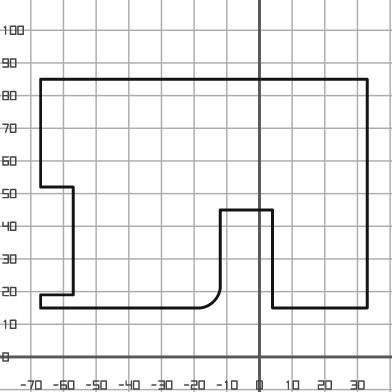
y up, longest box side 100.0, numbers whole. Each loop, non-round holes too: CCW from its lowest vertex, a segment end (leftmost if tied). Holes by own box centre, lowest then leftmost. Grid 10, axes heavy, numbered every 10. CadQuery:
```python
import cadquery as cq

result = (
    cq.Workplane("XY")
    .moveTo(-67.0, 15.0)
    .lineTo(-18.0, 15.0)
    .threePointArc((-14.0, 17.0), (-12.0, 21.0))
    .lineTo(-12.0, 45.0)
    .lineTo(4.0, 45.0)
    .lineTo(4.0, 15.0)
    .lineTo(33.0, 15.0)
    .lineTo(33.0, 85.0)
    .lineTo(-67.0, 85.0)
    .lineTo(-67.0, 52.0)
    .lineTo(-57.0, 52.0)
    .lineTo(-57.0, 19.0)
    .lineTo(-67.0, 19.0)
    .close()
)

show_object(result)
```